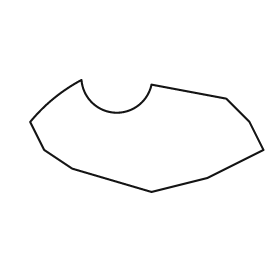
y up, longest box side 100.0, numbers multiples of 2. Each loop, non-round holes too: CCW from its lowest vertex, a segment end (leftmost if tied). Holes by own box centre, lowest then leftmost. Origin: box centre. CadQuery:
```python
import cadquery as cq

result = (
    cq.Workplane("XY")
    .moveTo(2.0, -24.0)
    .lineTo(26.0, -18.0)
    .lineTo(50.0, -6.0)
    .lineTo(44.0, 6.0)
    .lineTo(34.0, 16.0)
    .lineTo(2.0, 22.0)
    .threePointArc((-14.0, 10.0), (-28.0, 24.0))
    .threePointArc((-40.0, 16.0), (-50.0, 6.0))
    .lineTo(-44.0, -6.0)
    .lineTo(-32.0, -14.0)
    .close()
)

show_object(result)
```